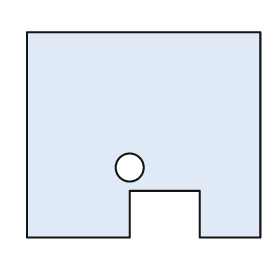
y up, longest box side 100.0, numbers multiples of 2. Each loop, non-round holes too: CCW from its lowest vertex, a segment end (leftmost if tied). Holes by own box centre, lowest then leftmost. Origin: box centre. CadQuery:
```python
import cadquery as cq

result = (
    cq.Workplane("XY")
    .moveTo(-50.0, -44.0)
    .lineTo(-6.0, -44.0)
    .lineTo(-6.0, -24.0)
    .lineTo(24.0, -24.0)
    .lineTo(24.0, -44.0)
    .lineTo(50.0, -44.0)
    .lineTo(50.0, 44.0)
    .lineTo(-50.0, 44.0)
    .close()
    .moveTo(-6.0, -14.0)
    .circle(6.0)
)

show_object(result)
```